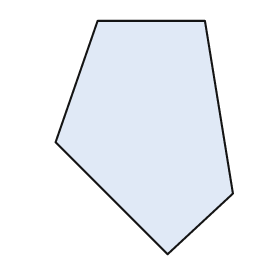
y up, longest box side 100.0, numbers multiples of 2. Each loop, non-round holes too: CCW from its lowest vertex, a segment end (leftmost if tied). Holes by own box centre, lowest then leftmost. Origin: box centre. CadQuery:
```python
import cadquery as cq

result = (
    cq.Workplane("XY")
    .moveTo(10.0, -50.0)
    .lineTo(38.0, -24.0)
    .lineTo(26.0, 50.0)
    .lineTo(-20.0, 50.0)
    .lineTo(-38.0, -2.0)
    .close()
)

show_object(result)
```